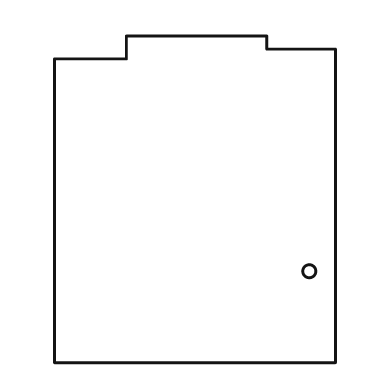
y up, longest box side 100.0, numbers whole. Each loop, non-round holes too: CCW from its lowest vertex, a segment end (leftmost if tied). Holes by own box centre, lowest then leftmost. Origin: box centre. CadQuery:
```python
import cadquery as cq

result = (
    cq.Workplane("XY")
    .moveTo(-43.0, -50.0)
    .lineTo(43.0, -50.0)
    .lineTo(43.0, 46.0)
    .lineTo(22.0, 46.0)
    .lineTo(22.0, 50.0)
    .lineTo(-21.0, 50.0)
    .lineTo(-21.0, 43.0)
    .lineTo(-43.0, 43.0)
    .close()
    .moveTo(35.0, -22.0)
    .circle(2.0)
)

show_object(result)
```